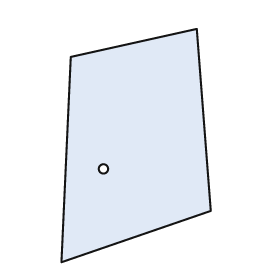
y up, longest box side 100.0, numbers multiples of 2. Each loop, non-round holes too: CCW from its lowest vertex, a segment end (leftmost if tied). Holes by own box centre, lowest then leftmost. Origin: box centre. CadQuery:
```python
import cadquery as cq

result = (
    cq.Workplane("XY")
    .moveTo(-32.0, -50.0)
    .lineTo(32.0, -28.0)
    .lineTo(26.0, 50.0)
    .lineTo(-28.0, 38.0)
    .close()
    .moveTo(-14.0, -10.0)
    .circle(2.0)
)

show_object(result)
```